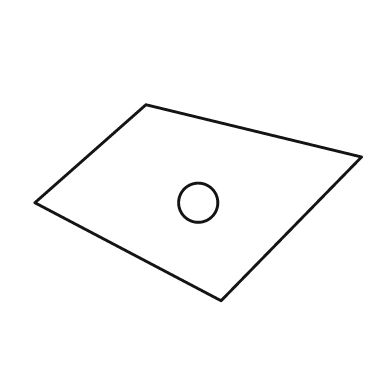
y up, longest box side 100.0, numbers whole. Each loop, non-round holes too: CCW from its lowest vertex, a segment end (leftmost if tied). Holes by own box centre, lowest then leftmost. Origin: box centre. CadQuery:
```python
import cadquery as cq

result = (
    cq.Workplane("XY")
    .moveTo(7.0, -30.0)
    .lineTo(50.0, 14.0)
    .lineTo(-16.0, 30.0)
    .lineTo(-50.0, 0.0)
    .close()
    .moveTo(0.0, 0.0)
    .circle(6.0)
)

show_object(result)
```